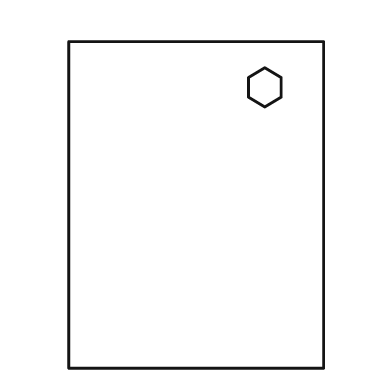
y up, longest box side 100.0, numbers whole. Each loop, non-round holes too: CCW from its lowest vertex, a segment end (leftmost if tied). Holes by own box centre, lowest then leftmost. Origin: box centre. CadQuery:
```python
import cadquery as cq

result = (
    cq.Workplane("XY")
    .moveTo(-39.0, -50.0)
    .lineTo(39.0, -50.0)
    .lineTo(39.0, 50.0)
    .lineTo(-39.0, 50.0)
    .close()
    .moveTo(21.0, 30.0)
    .lineTo(26.0, 33.0)
    .lineTo(26.0, 39.0)
    .lineTo(21.0, 42.0)
    .lineTo(16.0, 39.0)
    .lineTo(16.0, 33.0)
    .close()
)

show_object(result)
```